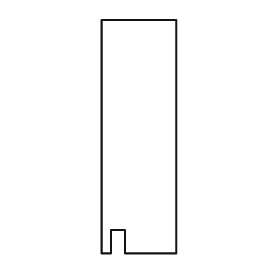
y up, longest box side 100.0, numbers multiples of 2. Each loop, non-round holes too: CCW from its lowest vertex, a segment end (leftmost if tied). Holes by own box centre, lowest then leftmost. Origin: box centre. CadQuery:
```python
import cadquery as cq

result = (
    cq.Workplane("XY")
    .moveTo(-16.0, -50.0)
    .lineTo(-12.0, -50.0)
    .lineTo(-12.0, -40.0)
    .lineTo(-6.0, -40.0)
    .lineTo(-6.0, -50.0)
    .lineTo(16.0, -50.0)
    .lineTo(16.0, 50.0)
    .lineTo(-16.0, 50.0)
    .close()
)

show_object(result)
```